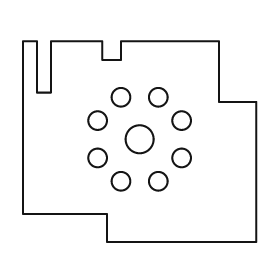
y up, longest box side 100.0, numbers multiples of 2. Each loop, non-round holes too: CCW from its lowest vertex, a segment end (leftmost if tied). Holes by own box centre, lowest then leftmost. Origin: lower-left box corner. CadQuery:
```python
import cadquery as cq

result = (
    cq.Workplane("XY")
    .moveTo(36.0, 0.0)
    .lineTo(100.0, 0.0)
    .lineTo(100.0, 60.0)
    .lineTo(84.0, 60.0)
    .lineTo(84.0, 86.0)
    .lineTo(42.0, 86.0)
    .lineTo(42.0, 78.0)
    .lineTo(34.0, 78.0)
    .lineTo(34.0, 86.0)
    .lineTo(12.0, 86.0)
    .lineTo(12.0, 64.0)
    .lineTo(6.0, 64.0)
    .lineTo(6.0, 86.0)
    .lineTo(0.0, 86.0)
    .lineTo(0.0, 12.0)
    .lineTo(36.0, 12.0)
    .close()
    .moveTo(42.0, 26.0)
    .circle(4.0)
    .moveTo(58.0, 26.0)
    .circle(4.0)
    .moveTo(32.0, 36.0)
    .circle(4.0)
    .moveTo(68.0, 36.0)
    .circle(4.0)
    .moveTo(50.0, 44.0)
    .circle(6.0)
    .moveTo(32.0, 52.0)
    .circle(4.0)
    .moveTo(68.0, 52.0)
    .circle(4.0)
    .moveTo(42.0, 62.0)
    .circle(4.0)
    .moveTo(58.0, 62.0)
    .circle(4.0)
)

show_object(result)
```